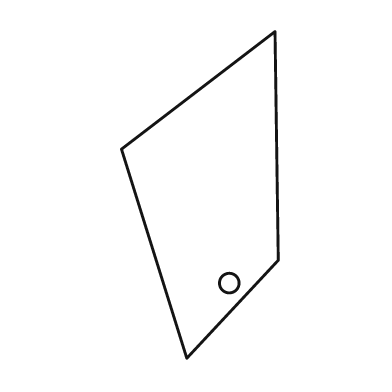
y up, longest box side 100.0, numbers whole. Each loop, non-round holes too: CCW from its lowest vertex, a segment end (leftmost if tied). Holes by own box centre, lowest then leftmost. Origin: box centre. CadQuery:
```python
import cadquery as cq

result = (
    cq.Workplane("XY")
    .moveTo(-4.0, -50.0)
    .lineTo(24.0, -20.0)
    .lineTo(23.0, 50.0)
    .lineTo(-24.0, 14.0)
    .close()
    .moveTo(9.0, -27.0)
    .circle(3.0)
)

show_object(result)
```